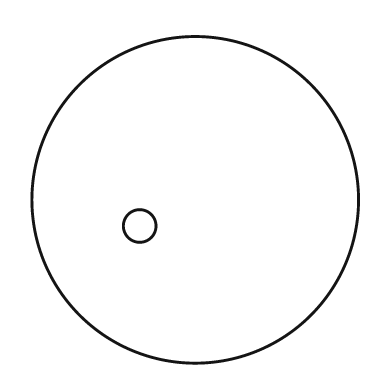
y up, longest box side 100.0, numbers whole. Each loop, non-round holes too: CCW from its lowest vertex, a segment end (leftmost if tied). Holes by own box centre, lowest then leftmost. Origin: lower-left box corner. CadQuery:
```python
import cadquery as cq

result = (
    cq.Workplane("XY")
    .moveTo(50.0, 50.0)
    .circle(50.0)
    .moveTo(33.0, 42.0)
    .circle(5.0)
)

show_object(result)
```